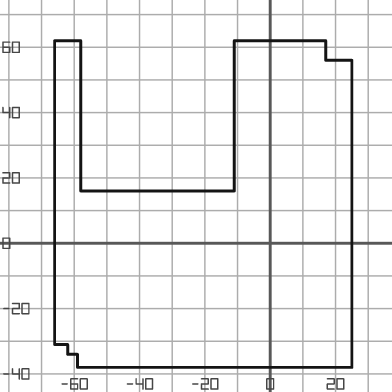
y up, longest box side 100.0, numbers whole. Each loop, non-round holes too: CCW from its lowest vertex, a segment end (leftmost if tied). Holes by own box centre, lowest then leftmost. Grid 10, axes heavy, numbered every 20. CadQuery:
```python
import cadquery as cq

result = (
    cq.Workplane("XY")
    .moveTo(-59.0, -38.0)
    .lineTo(25.0, -38.0)
    .lineTo(25.0, 56.0)
    .lineTo(17.0, 56.0)
    .lineTo(17.0, 62.0)
    .lineTo(-11.0, 62.0)
    .lineTo(-11.0, 16.0)
    .lineTo(-58.0, 16.0)
    .lineTo(-58.0, 62.0)
    .lineTo(-66.0, 62.0)
    .lineTo(-66.0, -31.0)
    .lineTo(-62.0, -31.0)
    .lineTo(-62.0, -34.0)
    .lineTo(-59.0, -34.0)
    .close()
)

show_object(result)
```